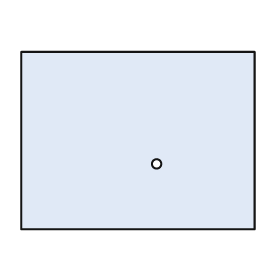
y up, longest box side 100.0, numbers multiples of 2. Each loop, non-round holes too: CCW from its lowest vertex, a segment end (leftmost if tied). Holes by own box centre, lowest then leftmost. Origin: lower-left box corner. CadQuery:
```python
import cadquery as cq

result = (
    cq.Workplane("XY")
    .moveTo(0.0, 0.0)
    .lineTo(100.0, 0.0)
    .lineTo(100.0, 76.0)
    .lineTo(0.0, 76.0)
    .close()
    .moveTo(58.0, 28.0)
    .circle(2.0)
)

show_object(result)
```